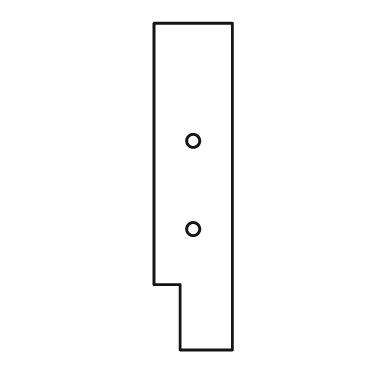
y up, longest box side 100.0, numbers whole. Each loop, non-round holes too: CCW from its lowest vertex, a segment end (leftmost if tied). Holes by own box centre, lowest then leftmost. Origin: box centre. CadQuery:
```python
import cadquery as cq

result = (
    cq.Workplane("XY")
    .moveTo(-4.0, -50.0)
    .lineTo(12.0, -50.0)
    .lineTo(12.0, 50.0)
    .lineTo(-12.0, 50.0)
    .lineTo(-12.0, -30.0)
    .lineTo(-4.0, -30.0)
    .close()
    .moveTo(0.0, -13.0)
    .circle(2.0)
    .moveTo(0.0, 14.0)
    .circle(2.0)
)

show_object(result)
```